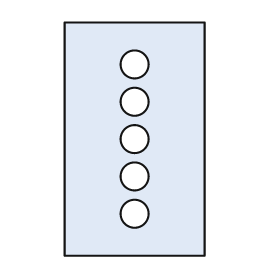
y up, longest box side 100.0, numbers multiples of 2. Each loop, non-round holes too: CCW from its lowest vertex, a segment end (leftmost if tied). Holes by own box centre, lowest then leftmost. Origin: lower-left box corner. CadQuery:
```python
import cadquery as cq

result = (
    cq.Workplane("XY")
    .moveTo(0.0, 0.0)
    .lineTo(60.0, 0.0)
    .lineTo(60.0, 100.0)
    .lineTo(0.0, 100.0)
    .close()
    .moveTo(30.0, 18.0)
    .circle(6.0)
    .moveTo(30.0, 34.0)
    .circle(6.0)
    .moveTo(30.0, 50.0)
    .circle(6.0)
    .moveTo(30.0, 66.0)
    .circle(6.0)
    .moveTo(30.0, 82.0)
    .circle(6.0)
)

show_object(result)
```